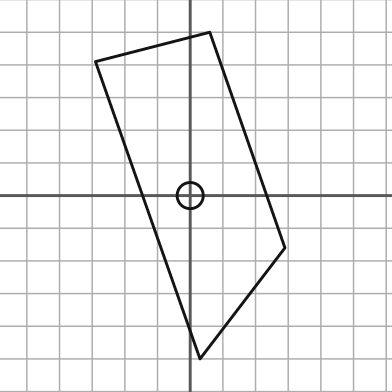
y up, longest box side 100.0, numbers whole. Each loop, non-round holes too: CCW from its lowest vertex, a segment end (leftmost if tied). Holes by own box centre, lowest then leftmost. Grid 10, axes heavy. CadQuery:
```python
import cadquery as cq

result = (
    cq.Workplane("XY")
    .moveTo(3.0, -50.0)
    .lineTo(29.0, -16.0)
    .lineTo(6.0, 50.0)
    .lineTo(-29.0, 41.0)
    .close()
    .moveTo(0.0, 0.0)
    .circle(4.0)
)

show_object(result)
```